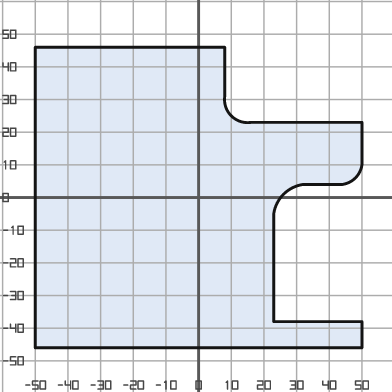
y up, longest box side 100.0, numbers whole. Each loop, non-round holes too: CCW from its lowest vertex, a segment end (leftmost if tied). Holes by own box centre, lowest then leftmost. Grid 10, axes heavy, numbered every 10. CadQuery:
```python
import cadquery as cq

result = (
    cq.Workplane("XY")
    .moveTo(-50.0, -46.0)
    .lineTo(50.0, -46.0)
    .lineTo(50.0, -38.0)
    .lineTo(23.0, -38.0)
    .lineTo(23.0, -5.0)
    .threePointArc((26.0, 1.0), (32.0, 4.0))
    .lineTo(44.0, 4.0)
    .threePointArc((48.0, 6.0), (50.0, 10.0))
    .lineTo(50.0, 23.0)
    .lineTo(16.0, 23.0)
    .threePointArc((10.0, 25.0), (8.0, 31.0))
    .lineTo(8.0, 46.0)
    .lineTo(-50.0, 46.0)
    .close()
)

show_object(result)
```